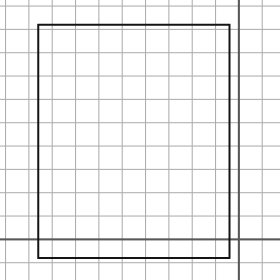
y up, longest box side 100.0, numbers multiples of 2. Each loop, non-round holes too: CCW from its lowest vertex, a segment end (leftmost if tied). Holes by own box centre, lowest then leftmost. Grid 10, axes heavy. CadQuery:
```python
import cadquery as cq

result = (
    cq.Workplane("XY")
    .moveTo(-86.0, -8.0)
    .lineTo(-4.0, -8.0)
    .lineTo(-4.0, 92.0)
    .lineTo(-86.0, 92.0)
    .close()
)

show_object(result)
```